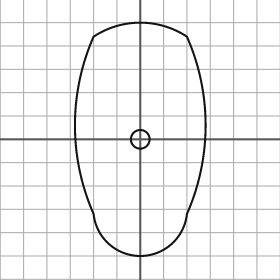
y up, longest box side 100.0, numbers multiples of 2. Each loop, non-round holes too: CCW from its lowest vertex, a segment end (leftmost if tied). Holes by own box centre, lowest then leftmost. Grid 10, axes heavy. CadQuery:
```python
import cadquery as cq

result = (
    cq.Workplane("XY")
    .moveTo(-20.0, -32.0)
    .threePointArc((0.0, -50.0), (20.0, -32.0))
    .threePointArc((28.0, 6.0), (20.0, 44.0))
    .threePointArc((0.0, 50.0), (-20.0, 44.0))
    .threePointArc((-28.0, 6.0), (-20.0, -32.0))
    .close()
    .moveTo(0.0, 0.0)
    .circle(4.0)
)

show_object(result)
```